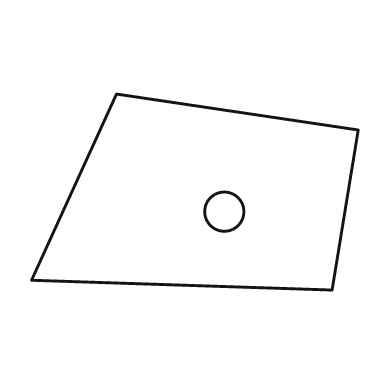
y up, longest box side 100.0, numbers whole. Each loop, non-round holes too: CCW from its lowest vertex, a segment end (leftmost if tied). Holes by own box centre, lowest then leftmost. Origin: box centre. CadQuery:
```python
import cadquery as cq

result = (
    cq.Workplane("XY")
    .moveTo(42.0, -30.0)
    .lineTo(50.0, 19.0)
    .lineTo(-24.0, 30.0)
    .lineTo(-50.0, -27.0)
    .close()
    .moveTo(9.0, -6.0)
    .circle(6.0)
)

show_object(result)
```